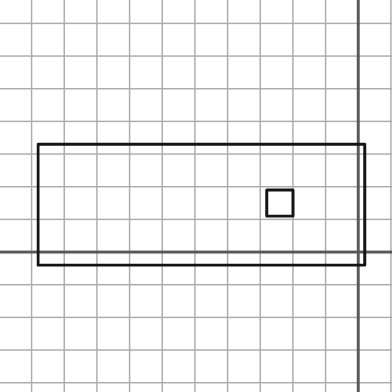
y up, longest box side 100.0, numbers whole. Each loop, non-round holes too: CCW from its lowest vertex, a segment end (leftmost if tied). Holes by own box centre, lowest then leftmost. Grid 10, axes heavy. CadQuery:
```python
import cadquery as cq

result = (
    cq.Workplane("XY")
    .moveTo(-98.0, -4.0)
    .lineTo(2.0, -4.0)
    .lineTo(2.0, 33.0)
    .lineTo(-98.0, 33.0)
    .close()
    .moveTo(-28.0, 11.0)
    .lineTo(-20.0, 11.0)
    .lineTo(-20.0, 19.0)
    .lineTo(-28.0, 19.0)
    .close()
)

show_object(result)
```